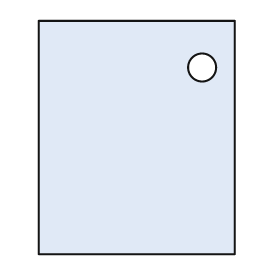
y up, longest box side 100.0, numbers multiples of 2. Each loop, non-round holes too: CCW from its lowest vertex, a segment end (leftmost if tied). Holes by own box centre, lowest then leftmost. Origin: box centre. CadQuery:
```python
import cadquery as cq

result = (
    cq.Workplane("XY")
    .moveTo(-42.0, -50.0)
    .lineTo(42.0, -50.0)
    .lineTo(42.0, 50.0)
    .lineTo(-42.0, 50.0)
    .close()
    .moveTo(28.0, 30.0)
    .circle(6.0)
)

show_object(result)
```